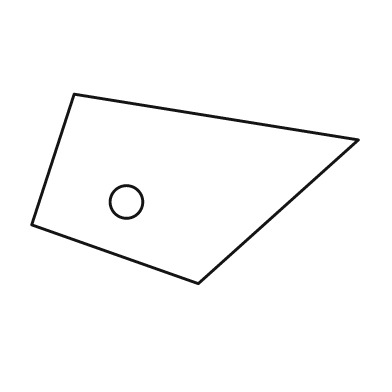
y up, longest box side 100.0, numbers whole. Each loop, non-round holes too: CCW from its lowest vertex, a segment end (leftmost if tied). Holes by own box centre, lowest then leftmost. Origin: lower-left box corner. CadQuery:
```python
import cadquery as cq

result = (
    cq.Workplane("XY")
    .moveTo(51.0, 0.0)
    .lineTo(100.0, 44.0)
    .lineTo(13.0, 58.0)
    .lineTo(0.0, 18.0)
    .close()
    .moveTo(29.0, 25.0)
    .circle(5.0)
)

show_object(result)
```